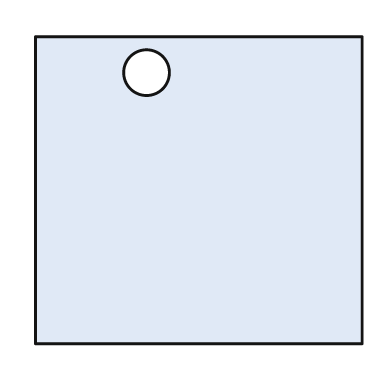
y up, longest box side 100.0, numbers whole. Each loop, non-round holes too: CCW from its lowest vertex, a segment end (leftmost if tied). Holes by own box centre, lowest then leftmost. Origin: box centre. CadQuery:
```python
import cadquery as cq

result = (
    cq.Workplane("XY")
    .moveTo(-50.0, -47.0)
    .lineTo(50.0, -47.0)
    .lineTo(50.0, 47.0)
    .lineTo(-50.0, 47.0)
    .close()
    .moveTo(-16.0, 36.0)
    .circle(7.0)
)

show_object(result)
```